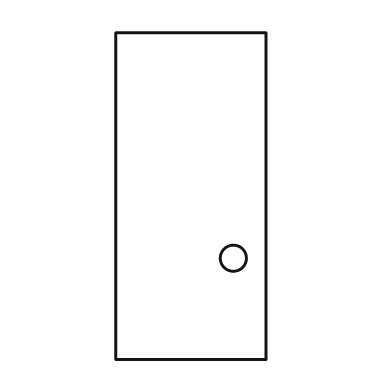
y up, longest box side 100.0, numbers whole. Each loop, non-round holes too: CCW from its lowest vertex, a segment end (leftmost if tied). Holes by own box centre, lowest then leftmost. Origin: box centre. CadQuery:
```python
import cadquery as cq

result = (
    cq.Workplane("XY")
    .moveTo(-23.0, -50.0)
    .lineTo(23.0, -50.0)
    .lineTo(23.0, 50.0)
    .lineTo(-23.0, 50.0)
    .close()
    .moveTo(13.0, -19.0)
    .circle(4.0)
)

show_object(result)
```